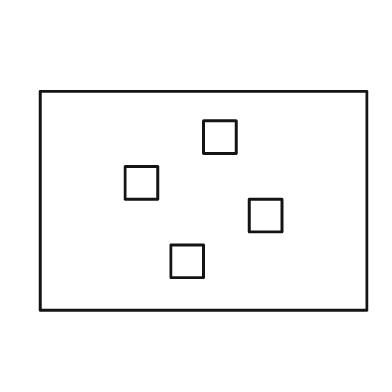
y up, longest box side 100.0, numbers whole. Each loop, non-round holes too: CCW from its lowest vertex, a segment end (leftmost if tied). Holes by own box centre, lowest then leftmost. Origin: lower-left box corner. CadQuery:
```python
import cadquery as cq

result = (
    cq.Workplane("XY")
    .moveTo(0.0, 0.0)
    .lineTo(100.0, 0.0)
    .lineTo(100.0, 67.0)
    .lineTo(0.0, 67.0)
    .close()
    .moveTo(40.0, 10.0)
    .lineTo(50.0, 10.0)
    .lineTo(50.0, 20.0)
    .lineTo(40.0, 20.0)
    .close()
    .moveTo(64.0, 24.0)
    .lineTo(74.0, 24.0)
    .lineTo(74.0, 34.0)
    .lineTo(64.0, 34.0)
    .close()
    .moveTo(26.0, 34.0)
    .lineTo(36.0, 34.0)
    .lineTo(36.0, 44.0)
    .lineTo(26.0, 44.0)
    .close()
    .moveTo(50.0, 48.0)
    .lineTo(60.0, 48.0)
    .lineTo(60.0, 58.0)
    .lineTo(50.0, 58.0)
    .close()
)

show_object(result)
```